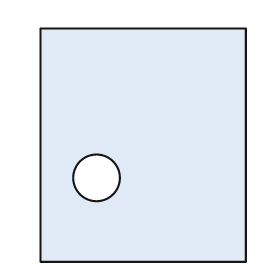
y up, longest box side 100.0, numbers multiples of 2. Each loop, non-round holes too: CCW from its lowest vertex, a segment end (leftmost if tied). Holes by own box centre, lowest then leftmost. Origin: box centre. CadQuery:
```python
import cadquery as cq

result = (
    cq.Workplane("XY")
    .moveTo(-44.0, -50.0)
    .lineTo(44.0, -50.0)
    .lineTo(44.0, 50.0)
    .lineTo(-44.0, 50.0)
    .close()
    .moveTo(-20.0, -14.0)
    .circle(10.0)
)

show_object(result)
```